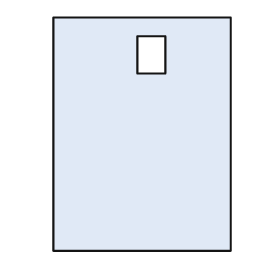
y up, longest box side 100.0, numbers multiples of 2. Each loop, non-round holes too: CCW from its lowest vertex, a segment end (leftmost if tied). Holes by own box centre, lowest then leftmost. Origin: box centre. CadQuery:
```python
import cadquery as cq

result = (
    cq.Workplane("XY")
    .moveTo(-38.0, -50.0)
    .lineTo(38.0, -50.0)
    .lineTo(38.0, 50.0)
    .lineTo(-38.0, 50.0)
    .close()
    .moveTo(-2.0, 26.0)
    .lineTo(10.0, 26.0)
    .lineTo(10.0, 42.0)
    .lineTo(-2.0, 42.0)
    .close()
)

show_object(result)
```